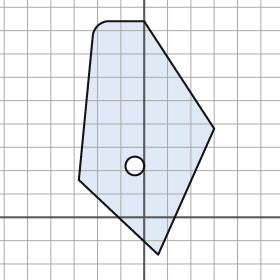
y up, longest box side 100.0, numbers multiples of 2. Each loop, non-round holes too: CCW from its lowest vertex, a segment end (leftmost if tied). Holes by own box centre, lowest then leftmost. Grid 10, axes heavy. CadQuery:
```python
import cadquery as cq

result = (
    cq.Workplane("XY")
    .moveTo(6.0, -16.0)
    .lineTo(30.0, 38.0)
    .lineTo(0.0, 84.0)
    .lineTo(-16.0, 84.0)
    .threePointArc((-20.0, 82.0), (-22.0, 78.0))
    .lineTo(-28.0, 16.0)
    .close()
    .moveTo(-4.0, 22.0)
    .circle(4.0)
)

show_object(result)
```